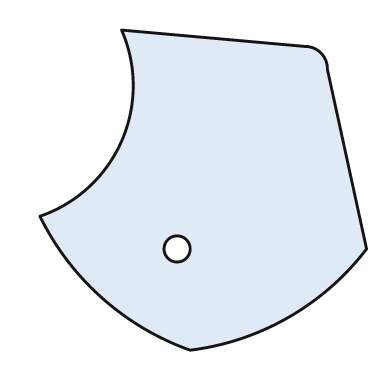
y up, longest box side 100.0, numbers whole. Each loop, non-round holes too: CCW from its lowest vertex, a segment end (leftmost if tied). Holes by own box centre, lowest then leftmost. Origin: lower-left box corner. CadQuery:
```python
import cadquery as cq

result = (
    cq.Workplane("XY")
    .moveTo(46.0, 0.0)
    .threePointArc((76.0, 10.0), (100.0, 31.0))
    .lineTo(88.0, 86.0)
    .threePointArc((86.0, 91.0), (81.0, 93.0))
    .lineTo(25.0, 98.0)
    .threePointArc((25.0, 64.0), (0.0, 41.0))
    .threePointArc((19.0, 16.0), (46.0, 0.0))
    .close()
    .moveTo(42.0, 31.0)
    .circle(4.0)
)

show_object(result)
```